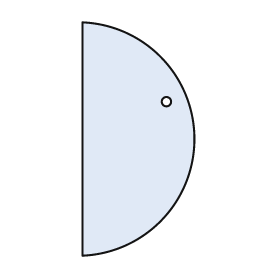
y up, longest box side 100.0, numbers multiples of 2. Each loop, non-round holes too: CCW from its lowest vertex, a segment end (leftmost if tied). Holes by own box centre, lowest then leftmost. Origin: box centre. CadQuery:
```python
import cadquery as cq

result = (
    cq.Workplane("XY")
    .moveTo(-24.0, -50.0)
    .threePointArc((24.0, 0.0), (-24.0, 50.0))
    .close()
    .moveTo(12.0, 16.0)
    .circle(2.0)
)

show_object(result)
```